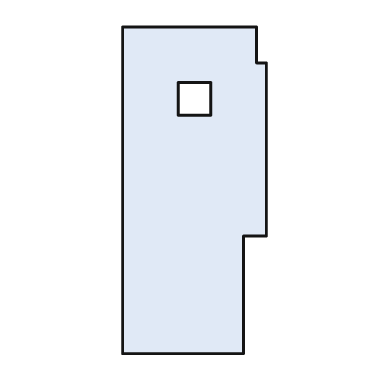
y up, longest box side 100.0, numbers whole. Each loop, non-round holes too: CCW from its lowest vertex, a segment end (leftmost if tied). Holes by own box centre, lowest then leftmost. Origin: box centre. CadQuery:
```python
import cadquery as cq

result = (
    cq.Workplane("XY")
    .moveTo(-22.0, -50.0)
    .lineTo(15.0, -50.0)
    .lineTo(15.0, -14.0)
    .lineTo(22.0, -14.0)
    .lineTo(22.0, 39.0)
    .lineTo(19.0, 39.0)
    .lineTo(19.0, 50.0)
    .lineTo(-22.0, 50.0)
    .close()
    .moveTo(-5.0, 23.0)
    .lineTo(5.0, 23.0)
    .lineTo(5.0, 33.0)
    .lineTo(-5.0, 33.0)
    .close()
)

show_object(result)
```